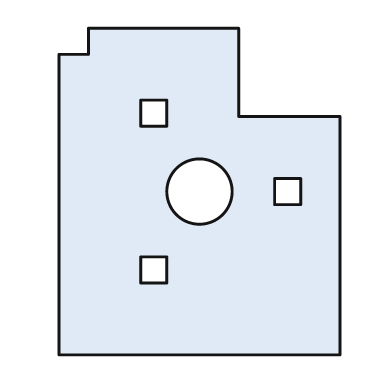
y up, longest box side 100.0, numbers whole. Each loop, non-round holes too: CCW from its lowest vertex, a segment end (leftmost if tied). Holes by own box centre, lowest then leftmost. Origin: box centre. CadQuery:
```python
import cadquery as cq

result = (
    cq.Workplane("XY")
    .moveTo(-43.0, -50.0)
    .lineTo(43.0, -50.0)
    .lineTo(43.0, 23.0)
    .lineTo(12.0, 23.0)
    .lineTo(12.0, 50.0)
    .lineTo(-34.0, 50.0)
    .lineTo(-34.0, 42.0)
    .lineTo(-43.0, 42.0)
    .close()
    .moveTo(-18.0, -28.0)
    .lineTo(-10.0, -28.0)
    .lineTo(-10.0, -20.0)
    .lineTo(-18.0, -20.0)
    .close()
    .moveTo(0.0, 0.0)
    .circle(10.0)
    .moveTo(23.0, -4.0)
    .lineTo(31.0, -4.0)
    .lineTo(31.0, 4.0)
    .lineTo(23.0, 4.0)
    .close()
    .moveTo(-18.0, 20.0)
    .lineTo(-10.0, 20.0)
    .lineTo(-10.0, 28.0)
    .lineTo(-18.0, 28.0)
    .close()
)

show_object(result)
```